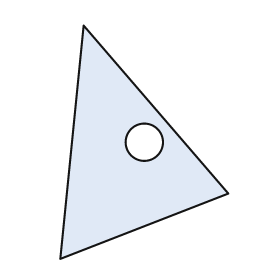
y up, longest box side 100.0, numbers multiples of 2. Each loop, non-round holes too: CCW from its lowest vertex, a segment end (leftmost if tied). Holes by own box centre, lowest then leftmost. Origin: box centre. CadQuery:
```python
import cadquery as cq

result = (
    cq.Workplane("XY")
    .moveTo(-36.0, -50.0)
    .lineTo(36.0, -22.0)
    .lineTo(-26.0, 50.0)
    .close()
    .moveTo(0.0, 0.0)
    .circle(8.0)
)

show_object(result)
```